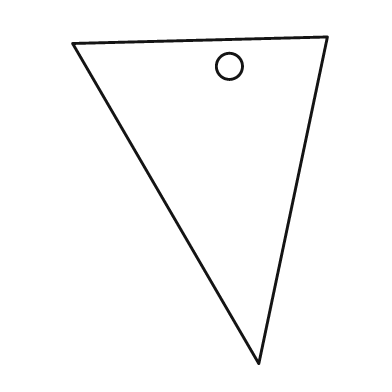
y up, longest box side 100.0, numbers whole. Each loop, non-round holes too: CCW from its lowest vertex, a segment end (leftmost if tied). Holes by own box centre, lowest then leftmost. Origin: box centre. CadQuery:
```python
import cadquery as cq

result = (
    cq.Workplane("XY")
    .moveTo(18.0, -50.0)
    .lineTo(39.0, 50.0)
    .lineTo(-39.0, 48.0)
    .close()
    .moveTo(9.0, 41.0)
    .circle(4.0)
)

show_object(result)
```